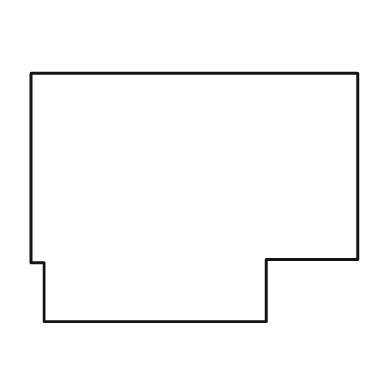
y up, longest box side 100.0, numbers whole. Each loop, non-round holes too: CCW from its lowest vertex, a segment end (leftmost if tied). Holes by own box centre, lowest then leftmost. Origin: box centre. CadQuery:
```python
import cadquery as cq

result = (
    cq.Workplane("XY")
    .moveTo(-46.0, -38.0)
    .lineTo(22.0, -38.0)
    .lineTo(22.0, -19.0)
    .lineTo(50.0, -19.0)
    .lineTo(50.0, 38.0)
    .lineTo(-50.0, 38.0)
    .lineTo(-50.0, -20.0)
    .lineTo(-46.0, -20.0)
    .close()
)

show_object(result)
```